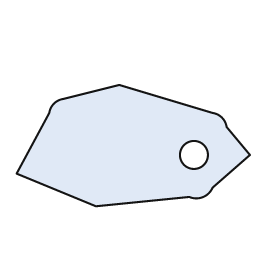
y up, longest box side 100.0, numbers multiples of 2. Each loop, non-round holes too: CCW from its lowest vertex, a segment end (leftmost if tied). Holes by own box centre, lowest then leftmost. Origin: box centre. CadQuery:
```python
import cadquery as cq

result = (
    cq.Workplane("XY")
    .moveTo(-16.0, -26.0)
    .lineTo(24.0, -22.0)
    .threePointArc((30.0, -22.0), (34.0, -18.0))
    .lineTo(50.0, -4.0)
    .lineTo(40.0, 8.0)
    .threePointArc((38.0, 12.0), (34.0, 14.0))
    .lineTo(-6.0, 26.0)
    .lineTo(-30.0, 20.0)
    .threePointArc((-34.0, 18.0), (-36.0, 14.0))
    .lineTo(-50.0, -12.0)
    .close()
    .moveTo(26.0, -4.0)
    .circle(6.0)
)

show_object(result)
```